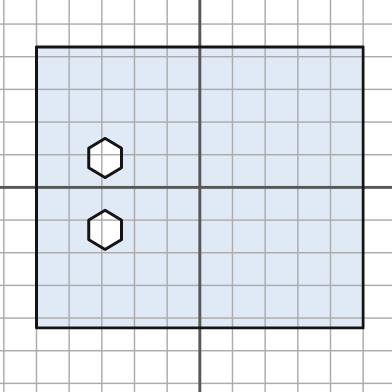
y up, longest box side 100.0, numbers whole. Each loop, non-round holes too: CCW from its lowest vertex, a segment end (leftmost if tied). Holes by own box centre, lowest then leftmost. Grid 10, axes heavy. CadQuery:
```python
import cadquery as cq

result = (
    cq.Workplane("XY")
    .moveTo(-50.0, -43.0)
    .lineTo(50.0, -43.0)
    .lineTo(50.0, 43.0)
    .lineTo(-50.0, 43.0)
    .close()
    .moveTo(-29.0, -19.0)
    .lineTo(-24.0, -16.0)
    .lineTo(-24.0, -10.0)
    .lineTo(-29.0, -7.0)
    .lineTo(-34.0, -10.0)
    .lineTo(-34.0, -16.0)
    .close()
    .moveTo(-29.0, 3.0)
    .lineTo(-24.0, 6.0)
    .lineTo(-24.0, 12.0)
    .lineTo(-29.0, 15.0)
    .lineTo(-34.0, 12.0)
    .lineTo(-34.0, 6.0)
    .close()
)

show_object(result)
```